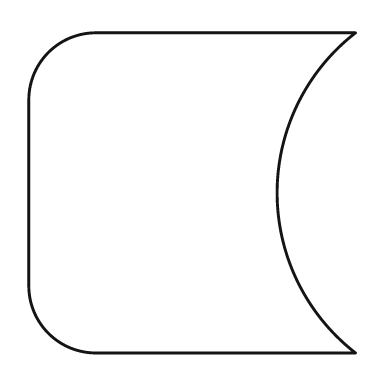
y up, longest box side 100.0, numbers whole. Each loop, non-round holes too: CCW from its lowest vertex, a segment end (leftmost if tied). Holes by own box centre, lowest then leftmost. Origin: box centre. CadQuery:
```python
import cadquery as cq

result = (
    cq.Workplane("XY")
    .moveTo(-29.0, -49.0)
    .lineTo(50.0, -49.0)
    .threePointArc((26.0, 0.0), (50.0, 49.0))
    .lineTo(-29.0, 49.0)
    .threePointArc((-44.0, 43.0), (-50.0, 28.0))
    .lineTo(-50.0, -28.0)
    .threePointArc((-44.0, -43.0), (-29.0, -49.0))
    .close()
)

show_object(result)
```